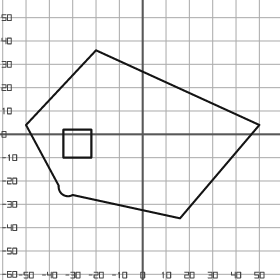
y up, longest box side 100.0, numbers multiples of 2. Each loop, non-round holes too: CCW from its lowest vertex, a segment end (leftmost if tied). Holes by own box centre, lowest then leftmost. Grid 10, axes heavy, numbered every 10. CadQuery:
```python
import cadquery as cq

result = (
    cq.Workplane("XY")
    .moveTo(16.0, -36.0)
    .lineTo(50.0, 4.0)
    .lineTo(-20.0, 36.0)
    .lineTo(-50.0, 4.0)
    .lineTo(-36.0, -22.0)
    .threePointArc((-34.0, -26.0), (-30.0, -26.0))
    .close()
    .moveTo(-34.0, -10.0)
    .lineTo(-22.0, -10.0)
    .lineTo(-22.0, 2.0)
    .lineTo(-34.0, 2.0)
    .close()
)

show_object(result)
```